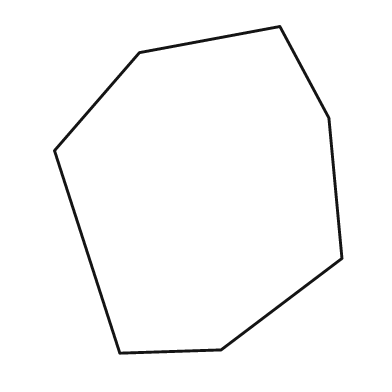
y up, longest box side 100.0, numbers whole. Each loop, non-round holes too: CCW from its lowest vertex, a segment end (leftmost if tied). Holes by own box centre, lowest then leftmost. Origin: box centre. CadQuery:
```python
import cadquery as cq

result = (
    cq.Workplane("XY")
    .moveTo(-24.0, -50.0)
    .lineTo(7.0, -49.0)
    .lineTo(44.0, -21.0)
    .lineTo(40.0, 22.0)
    .lineTo(25.0, 50.0)
    .lineTo(-18.0, 42.0)
    .lineTo(-44.0, 12.0)
    .close()
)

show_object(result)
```